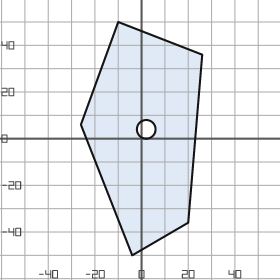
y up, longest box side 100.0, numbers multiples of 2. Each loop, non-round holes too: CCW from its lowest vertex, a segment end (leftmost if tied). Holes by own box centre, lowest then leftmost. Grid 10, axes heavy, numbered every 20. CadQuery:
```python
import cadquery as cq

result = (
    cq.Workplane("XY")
    .moveTo(-4.0, -50.0)
    .lineTo(20.0, -36.0)
    .lineTo(26.0, 36.0)
    .lineTo(-10.0, 50.0)
    .lineTo(-26.0, 6.0)
    .close()
    .moveTo(2.0, 4.0)
    .circle(4.0)
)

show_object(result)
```